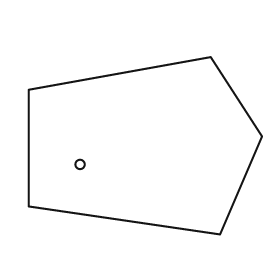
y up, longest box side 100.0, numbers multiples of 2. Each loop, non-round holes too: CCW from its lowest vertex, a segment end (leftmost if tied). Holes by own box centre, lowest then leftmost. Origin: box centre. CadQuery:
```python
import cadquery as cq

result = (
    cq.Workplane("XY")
    .moveTo(32.0, -38.0)
    .lineTo(50.0, 4.0)
    .lineTo(28.0, 38.0)
    .lineTo(-50.0, 24.0)
    .lineTo(-50.0, -26.0)
    .close()
    .moveTo(-28.0, -8.0)
    .circle(2.0)
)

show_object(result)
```